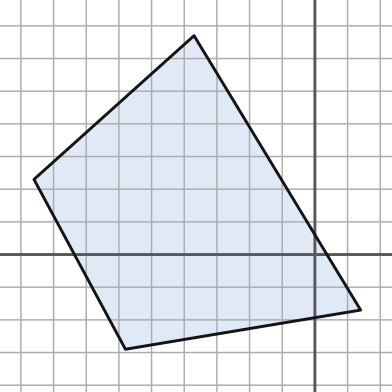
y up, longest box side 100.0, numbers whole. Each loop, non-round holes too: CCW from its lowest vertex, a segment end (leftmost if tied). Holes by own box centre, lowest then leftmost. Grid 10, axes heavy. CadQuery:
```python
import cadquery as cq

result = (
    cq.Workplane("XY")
    .moveTo(-58.0, -29.0)
    .lineTo(14.0, -17.0)
    .lineTo(-37.0, 67.0)
    .lineTo(-86.0, 23.0)
    .close()
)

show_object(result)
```